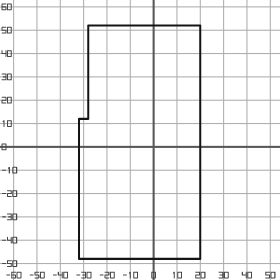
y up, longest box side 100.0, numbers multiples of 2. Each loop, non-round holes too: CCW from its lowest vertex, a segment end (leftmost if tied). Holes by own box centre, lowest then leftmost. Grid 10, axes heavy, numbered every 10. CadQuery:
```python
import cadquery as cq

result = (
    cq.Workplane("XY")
    .moveTo(-32.0, -48.0)
    .lineTo(20.0, -48.0)
    .lineTo(20.0, 52.0)
    .lineTo(-28.0, 52.0)
    .lineTo(-28.0, 12.0)
    .lineTo(-32.0, 12.0)
    .close()
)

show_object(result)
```